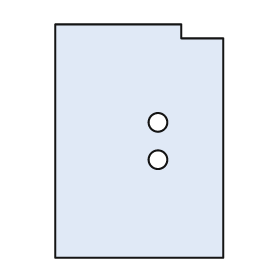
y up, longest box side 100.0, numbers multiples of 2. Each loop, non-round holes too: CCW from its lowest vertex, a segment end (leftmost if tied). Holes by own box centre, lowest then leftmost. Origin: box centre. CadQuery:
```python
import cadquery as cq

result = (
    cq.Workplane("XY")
    .moveTo(-36.0, -50.0)
    .lineTo(36.0, -50.0)
    .lineTo(36.0, 44.0)
    .lineTo(18.0, 44.0)
    .lineTo(18.0, 50.0)
    .lineTo(-36.0, 50.0)
    .close()
    .moveTo(8.0, -8.0)
    .circle(4.0)
    .moveTo(8.0, 8.0)
    .circle(4.0)
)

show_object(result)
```